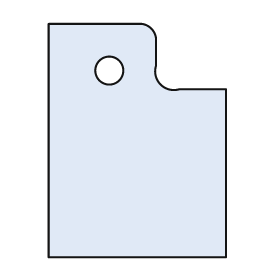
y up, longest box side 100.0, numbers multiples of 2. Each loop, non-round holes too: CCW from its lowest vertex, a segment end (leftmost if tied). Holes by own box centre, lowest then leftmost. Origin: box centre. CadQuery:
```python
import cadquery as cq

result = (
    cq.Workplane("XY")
    .moveTo(-38.0, -50.0)
    .lineTo(38.0, -50.0)
    .lineTo(38.0, 22.0)
    .lineTo(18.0, 22.0)
    .threePointArc((10.0, 24.0), (8.0, 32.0))
    .lineTo(8.0, 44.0)
    .threePointArc((6.0, 48.0), (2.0, 50.0))
    .lineTo(-38.0, 50.0)
    .close()
    .moveTo(-12.0, 30.0)
    .circle(6.0)
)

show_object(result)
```